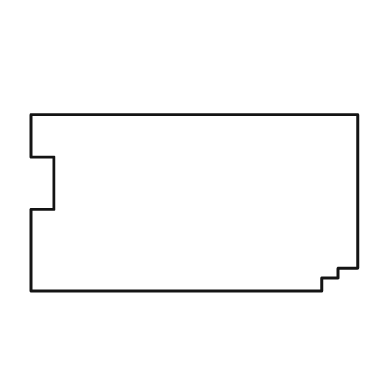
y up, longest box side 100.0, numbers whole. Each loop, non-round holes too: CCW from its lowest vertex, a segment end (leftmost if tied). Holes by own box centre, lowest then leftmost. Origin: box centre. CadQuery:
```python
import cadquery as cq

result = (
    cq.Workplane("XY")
    .moveTo(-50.0, -27.0)
    .lineTo(39.0, -27.0)
    .lineTo(39.0, -23.0)
    .lineTo(44.0, -23.0)
    .lineTo(44.0, -20.0)
    .lineTo(50.0, -20.0)
    .lineTo(50.0, 27.0)
    .lineTo(-50.0, 27.0)
    .lineTo(-50.0, 14.0)
    .lineTo(-43.0, 14.0)
    .lineTo(-43.0, -2.0)
    .lineTo(-50.0, -2.0)
    .close()
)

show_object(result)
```